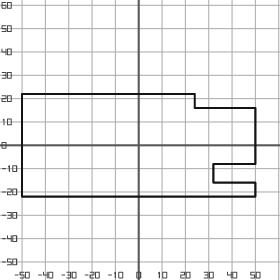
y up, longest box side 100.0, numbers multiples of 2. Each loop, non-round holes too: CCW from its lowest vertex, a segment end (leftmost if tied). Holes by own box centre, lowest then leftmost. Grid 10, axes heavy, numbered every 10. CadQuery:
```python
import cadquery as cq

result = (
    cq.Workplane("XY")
    .moveTo(-50.0, -22.0)
    .lineTo(50.0, -22.0)
    .lineTo(50.0, -16.0)
    .lineTo(32.0, -16.0)
    .lineTo(32.0, -8.0)
    .lineTo(50.0, -8.0)
    .lineTo(50.0, 16.0)
    .lineTo(24.0, 16.0)
    .lineTo(24.0, 22.0)
    .lineTo(-50.0, 22.0)
    .close()
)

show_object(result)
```